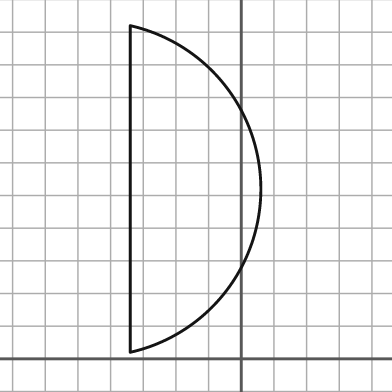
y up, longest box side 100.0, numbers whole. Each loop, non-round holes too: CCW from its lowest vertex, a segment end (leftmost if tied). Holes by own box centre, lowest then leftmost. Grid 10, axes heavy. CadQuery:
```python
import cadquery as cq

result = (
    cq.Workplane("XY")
    .moveTo(-34.0, 2.0)
    .threePointArc((6.0, 52.0), (-34.0, 102.0))
    .close()
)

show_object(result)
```